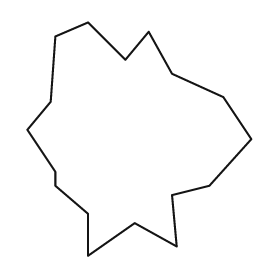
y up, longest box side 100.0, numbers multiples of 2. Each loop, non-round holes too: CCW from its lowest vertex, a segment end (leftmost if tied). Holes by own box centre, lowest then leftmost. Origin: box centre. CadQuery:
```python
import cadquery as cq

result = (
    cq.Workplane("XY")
    .moveTo(-22.0, -50.0)
    .lineTo(-2.0, -36.0)
    .lineTo(16.0, -46.0)
    .lineTo(14.0, -24.0)
    .lineTo(30.0, -20.0)
    .lineTo(48.0, 0.0)
    .lineTo(36.0, 18.0)
    .lineTo(14.0, 28.0)
    .lineTo(4.0, 46.0)
    .lineTo(-6.0, 34.0)
    .lineTo(-22.0, 50.0)
    .lineTo(-36.0, 44.0)
    .lineTo(-38.0, 16.0)
    .lineTo(-48.0, 4.0)
    .lineTo(-36.0, -14.0)
    .lineTo(-36.0, -20.0)
    .lineTo(-22.0, -32.0)
    .close()
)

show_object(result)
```